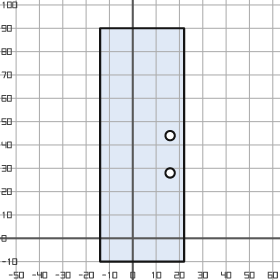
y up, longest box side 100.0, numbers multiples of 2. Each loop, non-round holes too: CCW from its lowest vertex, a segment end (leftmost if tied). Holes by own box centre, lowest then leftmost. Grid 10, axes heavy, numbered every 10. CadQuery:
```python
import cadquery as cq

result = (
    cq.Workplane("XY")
    .moveTo(-14.0, -10.0)
    .lineTo(22.0, -10.0)
    .lineTo(22.0, 90.0)
    .lineTo(-14.0, 90.0)
    .close()
    .moveTo(16.0, 28.0)
    .circle(2.0)
    .moveTo(16.0, 44.0)
    .circle(2.0)
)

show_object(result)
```